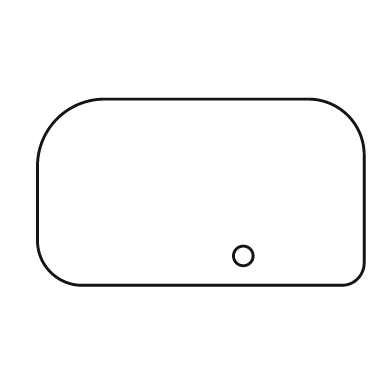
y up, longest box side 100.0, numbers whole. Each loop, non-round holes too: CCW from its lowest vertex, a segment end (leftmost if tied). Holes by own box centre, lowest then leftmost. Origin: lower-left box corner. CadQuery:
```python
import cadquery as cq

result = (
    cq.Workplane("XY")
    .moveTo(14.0, 0.0)
    .lineTo(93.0, 0.0)
    .threePointArc((98.0, 2.0), (100.0, 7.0))
    .lineTo(100.0, 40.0)
    .threePointArc((95.0, 52.0), (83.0, 57.0))
    .lineTo(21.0, 57.0)
    .threePointArc((6.0, 51.0), (0.0, 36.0))
    .lineTo(0.0, 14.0)
    .threePointArc((4.0, 4.0), (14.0, 0.0))
    .close()
    .moveTo(63.0, 9.0)
    .circle(3.0)
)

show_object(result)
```